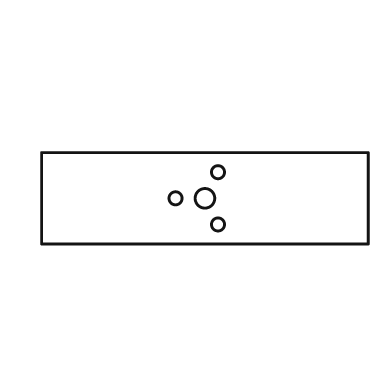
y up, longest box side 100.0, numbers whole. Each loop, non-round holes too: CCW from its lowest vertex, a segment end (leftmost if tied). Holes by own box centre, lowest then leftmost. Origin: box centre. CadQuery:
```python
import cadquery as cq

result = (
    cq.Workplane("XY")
    .moveTo(-50.0, -14.0)
    .lineTo(50.0, -14.0)
    .lineTo(50.0, 14.0)
    .lineTo(-50.0, 14.0)
    .close()
    .moveTo(4.0, -8.0)
    .circle(2.0)
    .moveTo(-9.0, 0.0)
    .circle(2.0)
    .moveTo(0.0, 0.0)
    .circle(3.0)
    .moveTo(4.0, 8.0)
    .circle(2.0)
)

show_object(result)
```